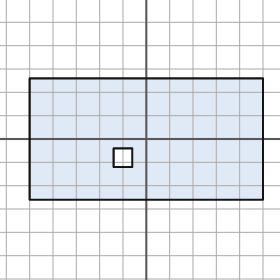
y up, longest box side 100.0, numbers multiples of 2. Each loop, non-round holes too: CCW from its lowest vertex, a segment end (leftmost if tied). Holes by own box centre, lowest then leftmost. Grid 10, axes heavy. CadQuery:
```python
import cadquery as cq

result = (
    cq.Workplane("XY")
    .moveTo(-50.0, -26.0)
    .lineTo(50.0, -26.0)
    .lineTo(50.0, 26.0)
    .lineTo(-50.0, 26.0)
    .close()
    .moveTo(-14.0, -12.0)
    .lineTo(-6.0, -12.0)
    .lineTo(-6.0, -4.0)
    .lineTo(-14.0, -4.0)
    .close()
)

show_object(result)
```